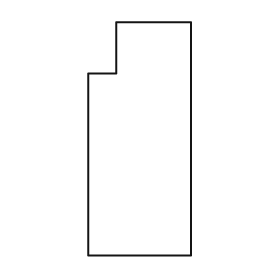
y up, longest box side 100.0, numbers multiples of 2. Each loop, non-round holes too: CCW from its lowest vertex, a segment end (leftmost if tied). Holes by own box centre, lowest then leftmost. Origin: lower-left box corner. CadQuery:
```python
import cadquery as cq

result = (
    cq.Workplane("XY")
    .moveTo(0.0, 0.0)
    .lineTo(44.0, 0.0)
    .lineTo(44.0, 100.0)
    .lineTo(12.0, 100.0)
    .lineTo(12.0, 78.0)
    .lineTo(0.0, 78.0)
    .close()
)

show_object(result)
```